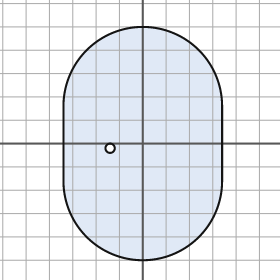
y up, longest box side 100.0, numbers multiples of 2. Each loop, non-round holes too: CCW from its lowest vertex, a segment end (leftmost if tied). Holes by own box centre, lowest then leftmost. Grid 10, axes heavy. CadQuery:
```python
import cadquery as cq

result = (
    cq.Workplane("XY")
    .moveTo(-34.0, -16.0)
    .threePointArc((0.0, -50.0), (34.0, -16.0))
    .lineTo(34.0, 16.0)
    .threePointArc((0.0, 50.0), (-34.0, 16.0))
    .close()
    .moveTo(-14.0, -2.0)
    .circle(2.0)
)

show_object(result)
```